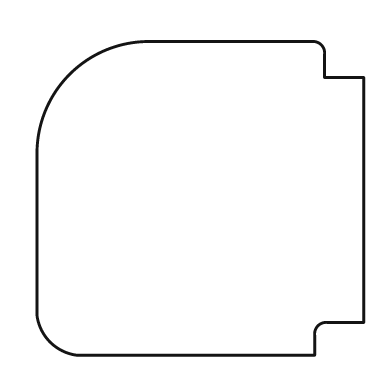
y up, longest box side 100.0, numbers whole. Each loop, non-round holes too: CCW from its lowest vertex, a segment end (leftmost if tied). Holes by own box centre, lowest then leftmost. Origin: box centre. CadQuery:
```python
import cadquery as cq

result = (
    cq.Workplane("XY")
    .moveTo(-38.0, -48.0)
    .lineTo(35.0, -48.0)
    .lineTo(35.0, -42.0)
    .threePointArc((36.0, -39.0), (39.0, -38.0))
    .lineTo(50.0, -38.0)
    .lineTo(50.0, 37.0)
    .lineTo(38.0, 37.0)
    .lineTo(38.0, 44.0)
    .threePointArc((37.0, 47.0), (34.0, 48.0))
    .lineTo(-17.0, 48.0)
    .threePointArc((-40.0, 38.0), (-50.0, 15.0))
    .lineTo(-50.0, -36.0)
    .threePointArc((-46.0, -44.0), (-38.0, -48.0))
    .close()
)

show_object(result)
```